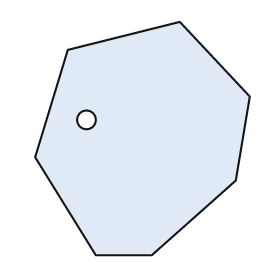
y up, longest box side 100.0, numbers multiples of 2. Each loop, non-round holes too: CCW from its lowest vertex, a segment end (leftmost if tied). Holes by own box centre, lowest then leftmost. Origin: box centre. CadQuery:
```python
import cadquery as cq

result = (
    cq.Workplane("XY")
    .moveTo(-20.0, -50.0)
    .lineTo(4.0, -50.0)
    .lineTo(40.0, -18.0)
    .lineTo(46.0, 18.0)
    .lineTo(16.0, 50.0)
    .lineTo(-32.0, 38.0)
    .lineTo(-46.0, -8.0)
    .close()
    .moveTo(-24.0, 8.0)
    .circle(4.0)
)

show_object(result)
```